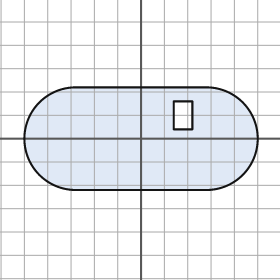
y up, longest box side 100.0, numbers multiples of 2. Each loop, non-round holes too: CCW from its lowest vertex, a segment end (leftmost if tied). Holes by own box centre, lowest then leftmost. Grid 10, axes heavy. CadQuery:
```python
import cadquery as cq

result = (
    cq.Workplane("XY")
    .moveTo(-28.0, -22.0)
    .lineTo(28.0, -22.0)
    .threePointArc((50.0, 0.0), (28.0, 22.0))
    .lineTo(-28.0, 22.0)
    .threePointArc((-50.0, 0.0), (-28.0, -22.0))
    .close()
    .moveTo(14.0, 4.0)
    .lineTo(22.0, 4.0)
    .lineTo(22.0, 16.0)
    .lineTo(14.0, 16.0)
    .close()
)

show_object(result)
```